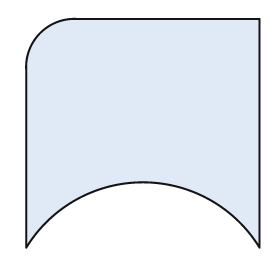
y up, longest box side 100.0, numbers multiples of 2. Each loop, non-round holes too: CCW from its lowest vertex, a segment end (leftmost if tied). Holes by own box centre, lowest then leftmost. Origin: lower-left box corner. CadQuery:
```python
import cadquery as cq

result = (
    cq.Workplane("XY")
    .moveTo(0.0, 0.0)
    .threePointArc((50.0, 28.0), (100.0, 0.0))
    .lineTo(100.0, 98.0)
    .lineTo(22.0, 98.0)
    .threePointArc((6.0, 92.0), (0.0, 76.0))
    .close()
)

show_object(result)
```